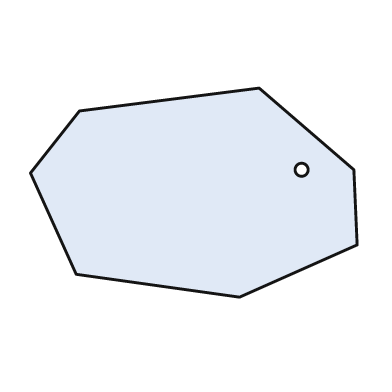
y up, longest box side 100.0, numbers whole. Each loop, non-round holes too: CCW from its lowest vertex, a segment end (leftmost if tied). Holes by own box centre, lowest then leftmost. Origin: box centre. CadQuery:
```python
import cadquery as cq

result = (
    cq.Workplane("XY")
    .moveTo(14.0, -32.0)
    .lineTo(50.0, -16.0)
    .lineTo(49.0, 7.0)
    .lineTo(20.0, 32.0)
    .lineTo(-35.0, 25.0)
    .lineTo(-50.0, 6.0)
    .lineTo(-36.0, -25.0)
    .close()
    .moveTo(33.0, 7.0)
    .circle(2.0)
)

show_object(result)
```